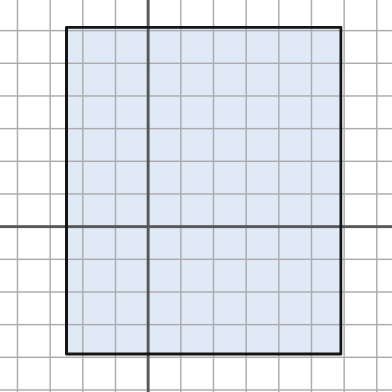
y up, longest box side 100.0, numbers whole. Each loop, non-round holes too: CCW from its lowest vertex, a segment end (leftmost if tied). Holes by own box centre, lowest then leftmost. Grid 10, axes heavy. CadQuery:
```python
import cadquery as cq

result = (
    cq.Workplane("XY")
    .moveTo(-25.0, -39.0)
    .lineTo(59.0, -39.0)
    .lineTo(59.0, 61.0)
    .lineTo(-25.0, 61.0)
    .close()
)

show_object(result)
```